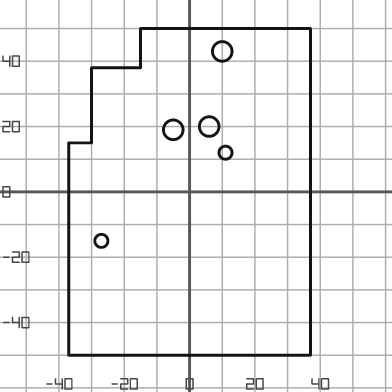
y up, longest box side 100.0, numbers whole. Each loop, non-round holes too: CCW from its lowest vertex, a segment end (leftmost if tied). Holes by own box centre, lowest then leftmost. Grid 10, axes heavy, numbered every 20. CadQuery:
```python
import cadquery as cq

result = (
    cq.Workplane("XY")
    .moveTo(-37.0, -50.0)
    .lineTo(37.0, -50.0)
    .lineTo(37.0, 50.0)
    .lineTo(-15.0, 50.0)
    .lineTo(-15.0, 38.0)
    .lineTo(-30.0, 38.0)
    .lineTo(-30.0, 15.0)
    .lineTo(-37.0, 15.0)
    .close()
    .moveTo(-27.0, -15.0)
    .circle(2.0)
    .moveTo(11.0, 12.0)
    .circle(2.0)
    .moveTo(-5.0, 19.0)
    .circle(3.0)
    .moveTo(6.0, 20.0)
    .circle(3.0)
    .moveTo(10.0, 43.0)
    .circle(3.0)
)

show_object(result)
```